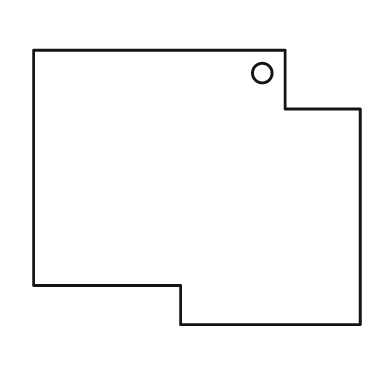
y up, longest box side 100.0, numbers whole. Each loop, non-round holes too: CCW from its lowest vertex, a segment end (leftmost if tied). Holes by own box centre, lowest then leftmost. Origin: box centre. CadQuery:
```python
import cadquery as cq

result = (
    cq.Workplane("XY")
    .moveTo(-5.0, -42.0)
    .lineTo(50.0, -42.0)
    .lineTo(50.0, 24.0)
    .lineTo(27.0, 24.0)
    .lineTo(27.0, 42.0)
    .lineTo(-50.0, 42.0)
    .lineTo(-50.0, -30.0)
    .lineTo(-5.0, -30.0)
    .close()
    .moveTo(20.0, 35.0)
    .circle(3.0)
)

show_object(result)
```